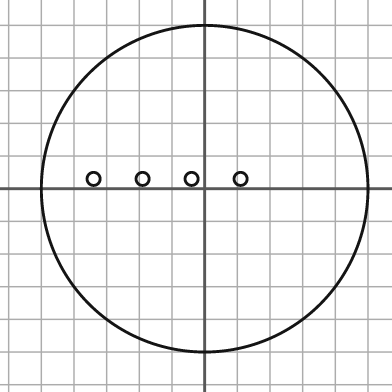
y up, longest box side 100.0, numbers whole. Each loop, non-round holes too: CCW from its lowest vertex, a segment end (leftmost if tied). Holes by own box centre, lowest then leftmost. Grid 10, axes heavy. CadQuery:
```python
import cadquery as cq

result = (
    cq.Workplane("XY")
    .moveTo(0.0, 0.0)
    .circle(50.0)
    .moveTo(-34.0, 3.0)
    .circle(2.0)
    .moveTo(-19.0, 3.0)
    .circle(2.0)
    .moveTo(-4.0, 3.0)
    .circle(2.0)
    .moveTo(11.0, 3.0)
    .circle(2.0)
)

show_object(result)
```